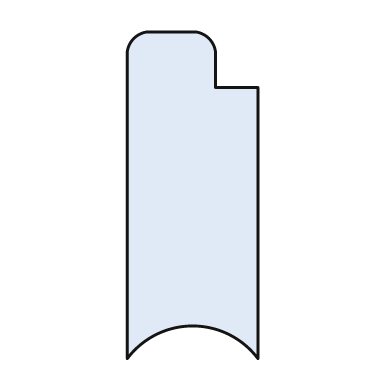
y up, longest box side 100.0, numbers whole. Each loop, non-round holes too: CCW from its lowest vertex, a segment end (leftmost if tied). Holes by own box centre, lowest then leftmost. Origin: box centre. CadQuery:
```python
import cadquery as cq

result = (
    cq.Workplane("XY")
    .moveTo(-20.0, -50.0)
    .threePointArc((0.0, -40.0), (20.0, -50.0))
    .lineTo(20.0, 33.0)
    .lineTo(7.0, 33.0)
    .lineTo(7.0, 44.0)
    .threePointArc((5.0, 48.0), (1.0, 50.0))
    .lineTo(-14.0, 50.0)
    .threePointArc((-18.0, 48.0), (-20.0, 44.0))
    .close()
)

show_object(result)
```